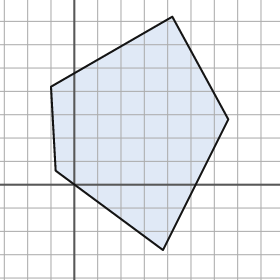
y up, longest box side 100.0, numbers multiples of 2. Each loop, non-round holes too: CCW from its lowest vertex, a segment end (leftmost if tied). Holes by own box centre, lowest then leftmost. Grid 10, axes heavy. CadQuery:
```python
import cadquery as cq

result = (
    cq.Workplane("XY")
    .moveTo(38.0, -28.0)
    .lineTo(66.0, 28.0)
    .lineTo(42.0, 72.0)
    .lineTo(-10.0, 42.0)
    .lineTo(-8.0, 6.0)
    .close()
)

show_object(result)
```